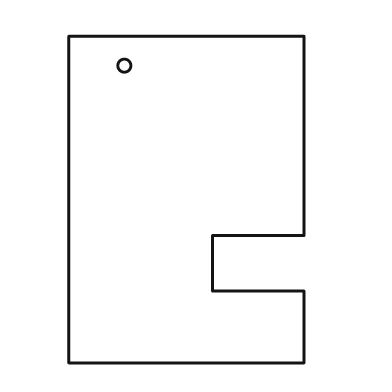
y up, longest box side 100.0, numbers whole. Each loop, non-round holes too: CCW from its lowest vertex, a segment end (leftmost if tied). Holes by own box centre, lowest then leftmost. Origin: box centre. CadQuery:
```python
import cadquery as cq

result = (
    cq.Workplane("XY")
    .moveTo(-36.0, -50.0)
    .lineTo(36.0, -50.0)
    .lineTo(36.0, -28.0)
    .lineTo(8.0, -28.0)
    .lineTo(8.0, -11.0)
    .lineTo(36.0, -11.0)
    .lineTo(36.0, 50.0)
    .lineTo(-36.0, 50.0)
    .close()
    .moveTo(-19.0, 41.0)
    .circle(2.0)
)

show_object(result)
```